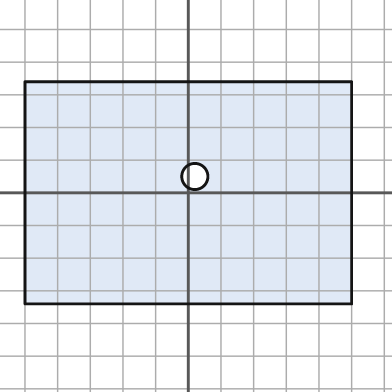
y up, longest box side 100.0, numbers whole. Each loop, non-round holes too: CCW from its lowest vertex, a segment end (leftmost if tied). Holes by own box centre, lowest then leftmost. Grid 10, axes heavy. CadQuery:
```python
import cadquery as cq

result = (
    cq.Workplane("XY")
    .moveTo(-50.0, -34.0)
    .lineTo(50.0, -34.0)
    .lineTo(50.0, 34.0)
    .lineTo(-50.0, 34.0)
    .close()
    .moveTo(2.0, 5.0)
    .circle(4.0)
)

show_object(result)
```